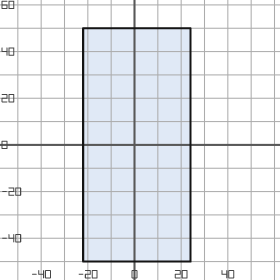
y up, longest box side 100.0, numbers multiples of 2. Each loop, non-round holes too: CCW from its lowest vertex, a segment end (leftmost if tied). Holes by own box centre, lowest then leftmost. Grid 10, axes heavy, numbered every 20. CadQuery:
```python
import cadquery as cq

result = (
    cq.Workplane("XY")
    .moveTo(-22.0, -50.0)
    .lineTo(24.0, -50.0)
    .lineTo(24.0, 50.0)
    .lineTo(-22.0, 50.0)
    .close()
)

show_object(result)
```